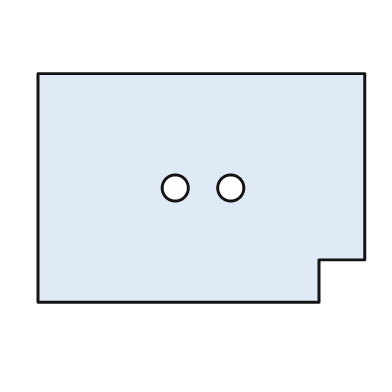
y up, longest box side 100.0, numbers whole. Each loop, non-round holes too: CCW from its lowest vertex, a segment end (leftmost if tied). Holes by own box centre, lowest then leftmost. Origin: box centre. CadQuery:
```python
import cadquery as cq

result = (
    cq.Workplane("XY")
    .moveTo(-50.0, -35.0)
    .lineTo(36.0, -35.0)
    .lineTo(36.0, -22.0)
    .lineTo(50.0, -22.0)
    .lineTo(50.0, 35.0)
    .lineTo(-50.0, 35.0)
    .close()
    .moveTo(-8.0, 0.0)
    .circle(4.0)
    .moveTo(9.0, 0.0)
    .circle(4.0)
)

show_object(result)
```